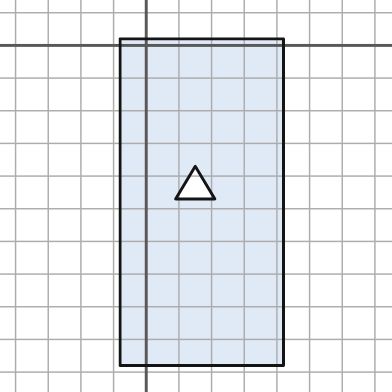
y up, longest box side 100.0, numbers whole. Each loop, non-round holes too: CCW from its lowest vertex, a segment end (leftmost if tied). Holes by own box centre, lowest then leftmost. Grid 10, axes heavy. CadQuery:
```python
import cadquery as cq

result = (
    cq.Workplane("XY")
    .moveTo(-8.0, -98.0)
    .lineTo(42.0, -98.0)
    .lineTo(42.0, 2.0)
    .lineTo(-8.0, 2.0)
    .close()
    .moveTo(9.0, -47.0)
    .lineTo(21.0, -47.0)
    .lineTo(15.0, -37.0)
    .close()
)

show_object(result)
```